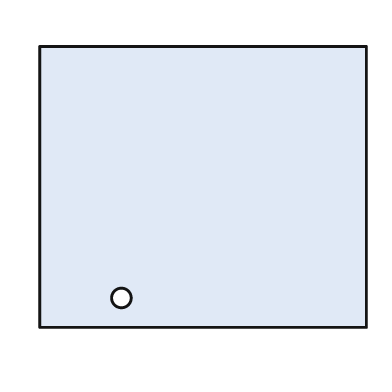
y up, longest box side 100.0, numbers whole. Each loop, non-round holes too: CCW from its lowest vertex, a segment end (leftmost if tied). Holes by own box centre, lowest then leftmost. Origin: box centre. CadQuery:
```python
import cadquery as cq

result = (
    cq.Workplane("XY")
    .moveTo(-50.0, -43.0)
    .lineTo(50.0, -43.0)
    .lineTo(50.0, 43.0)
    .lineTo(-50.0, 43.0)
    .close()
    .moveTo(-25.0, -34.0)
    .circle(3.0)
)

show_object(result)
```